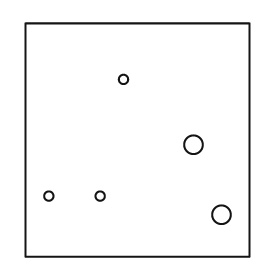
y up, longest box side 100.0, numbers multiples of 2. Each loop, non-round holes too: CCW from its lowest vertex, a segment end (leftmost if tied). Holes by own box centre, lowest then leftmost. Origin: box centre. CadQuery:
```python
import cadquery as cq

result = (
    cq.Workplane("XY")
    .moveTo(-48.0, -50.0)
    .lineTo(48.0, -50.0)
    .lineTo(48.0, 50.0)
    .lineTo(-48.0, 50.0)
    .close()
    .moveTo(36.0, -32.0)
    .circle(4.0)
    .moveTo(-38.0, -24.0)
    .circle(2.0)
    .moveTo(-16.0, -24.0)
    .circle(2.0)
    .moveTo(24.0, -2.0)
    .circle(4.0)
    .moveTo(-6.0, 26.0)
    .circle(2.0)
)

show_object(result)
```